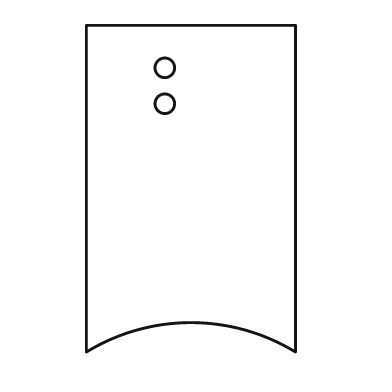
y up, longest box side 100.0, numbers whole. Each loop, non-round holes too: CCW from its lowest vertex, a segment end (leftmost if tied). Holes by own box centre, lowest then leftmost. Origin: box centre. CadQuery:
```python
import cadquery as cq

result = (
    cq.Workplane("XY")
    .moveTo(-32.0, -50.0)
    .threePointArc((0.0, -41.0), (32.0, -50.0))
    .lineTo(32.0, 50.0)
    .lineTo(-32.0, 50.0)
    .close()
    .moveTo(-8.0, 26.0)
    .circle(3.0)
    .moveTo(-8.0, 37.0)
    .circle(3.0)
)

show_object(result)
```